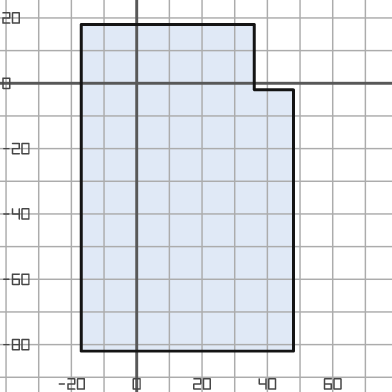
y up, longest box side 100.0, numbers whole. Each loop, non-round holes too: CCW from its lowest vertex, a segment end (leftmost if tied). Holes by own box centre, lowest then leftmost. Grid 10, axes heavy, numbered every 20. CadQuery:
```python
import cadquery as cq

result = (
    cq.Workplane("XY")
    .moveTo(-17.0, -82.0)
    .lineTo(48.0, -82.0)
    .lineTo(48.0, -2.0)
    .lineTo(36.0, -2.0)
    .lineTo(36.0, 18.0)
    .lineTo(-17.0, 18.0)
    .close()
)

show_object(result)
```